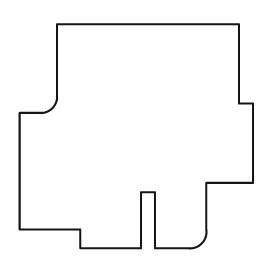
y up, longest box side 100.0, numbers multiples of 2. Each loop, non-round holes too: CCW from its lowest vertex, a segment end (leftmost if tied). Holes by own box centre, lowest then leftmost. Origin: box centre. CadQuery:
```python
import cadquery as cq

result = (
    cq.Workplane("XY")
    .moveTo(-24.0, -48.0)
    .lineTo(2.0, -48.0)
    .lineTo(2.0, -24.0)
    .lineTo(8.0, -24.0)
    .lineTo(8.0, -48.0)
    .lineTo(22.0, -48.0)
    .threePointArc((28.0, -46.0), (30.0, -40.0))
    .lineTo(30.0, -20.0)
    .lineTo(50.0, -20.0)
    .lineTo(50.0, 14.0)
    .lineTo(44.0, 14.0)
    .lineTo(44.0, 48.0)
    .lineTo(-34.0, 48.0)
    .lineTo(-34.0, 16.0)
    .threePointArc((-36.0, 12.0), (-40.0, 10.0))
    .lineTo(-50.0, 10.0)
    .lineTo(-50.0, -40.0)
    .lineTo(-24.0, -40.0)
    .close()
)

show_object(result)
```